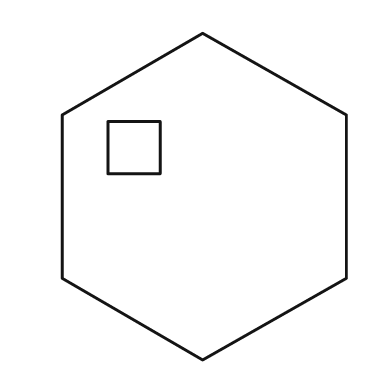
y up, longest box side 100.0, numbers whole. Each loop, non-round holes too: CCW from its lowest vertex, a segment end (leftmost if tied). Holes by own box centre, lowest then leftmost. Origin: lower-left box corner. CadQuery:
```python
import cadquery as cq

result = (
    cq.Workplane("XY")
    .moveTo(43.0, 0.0)
    .lineTo(87.0, 25.0)
    .lineTo(87.0, 75.0)
    .lineTo(43.0, 100.0)
    .lineTo(0.0, 75.0)
    .lineTo(0.0, 25.0)
    .close()
    .moveTo(14.0, 57.0)
    .lineTo(30.0, 57.0)
    .lineTo(30.0, 73.0)
    .lineTo(14.0, 73.0)
    .close()
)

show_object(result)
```